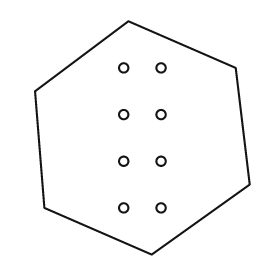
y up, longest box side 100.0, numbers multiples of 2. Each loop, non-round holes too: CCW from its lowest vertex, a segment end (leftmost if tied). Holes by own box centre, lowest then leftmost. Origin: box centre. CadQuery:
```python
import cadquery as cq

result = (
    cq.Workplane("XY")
    .moveTo(4.0, -50.0)
    .lineTo(46.0, -20.0)
    .lineTo(40.0, 30.0)
    .lineTo(-6.0, 50.0)
    .lineTo(-46.0, 20.0)
    .lineTo(-42.0, -30.0)
    .close()
    .moveTo(-8.0, -30.0)
    .circle(2.0)
    .moveTo(8.0, -30.0)
    .circle(2.0)
    .moveTo(-8.0, -10.0)
    .circle(2.0)
    .moveTo(8.0, -10.0)
    .circle(2.0)
    .moveTo(-8.0, 10.0)
    .circle(2.0)
    .moveTo(8.0, 10.0)
    .circle(2.0)
    .moveTo(-8.0, 30.0)
    .circle(2.0)
    .moveTo(8.0, 30.0)
    .circle(2.0)
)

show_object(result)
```